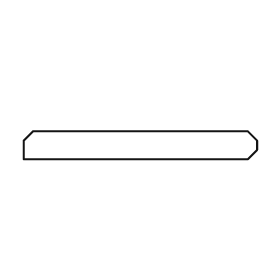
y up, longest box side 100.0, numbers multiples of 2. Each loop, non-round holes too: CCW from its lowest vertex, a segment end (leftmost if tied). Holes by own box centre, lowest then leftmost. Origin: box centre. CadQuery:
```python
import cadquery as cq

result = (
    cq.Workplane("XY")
    .moveTo(-50.0, -6.0)
    .lineTo(46.0, -6.0)
    .lineTo(50.0, -2.0)
    .lineTo(50.0, 2.0)
    .lineTo(46.0, 6.0)
    .lineTo(-46.0, 6.0)
    .lineTo(-50.0, 2.0)
    .close()
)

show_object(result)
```